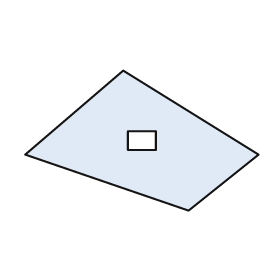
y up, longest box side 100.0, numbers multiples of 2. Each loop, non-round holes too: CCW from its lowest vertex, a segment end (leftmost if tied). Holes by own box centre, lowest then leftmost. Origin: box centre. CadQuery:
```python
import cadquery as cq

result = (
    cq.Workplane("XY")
    .moveTo(20.0, -30.0)
    .lineTo(50.0, -6.0)
    .lineTo(-8.0, 30.0)
    .lineTo(-50.0, -6.0)
    .close()
    .moveTo(-6.0, -4.0)
    .lineTo(6.0, -4.0)
    .lineTo(6.0, 4.0)
    .lineTo(-6.0, 4.0)
    .close()
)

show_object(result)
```